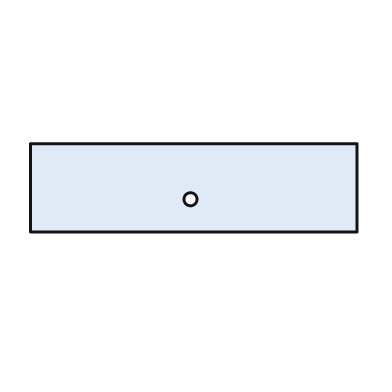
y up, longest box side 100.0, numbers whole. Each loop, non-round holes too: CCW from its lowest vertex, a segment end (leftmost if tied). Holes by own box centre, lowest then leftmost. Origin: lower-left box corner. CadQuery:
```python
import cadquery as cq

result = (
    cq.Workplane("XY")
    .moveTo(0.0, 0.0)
    .lineTo(100.0, 0.0)
    .lineTo(100.0, 27.0)
    .lineTo(0.0, 27.0)
    .close()
    .moveTo(49.0, 10.0)
    .circle(2.0)
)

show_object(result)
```